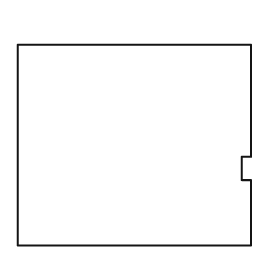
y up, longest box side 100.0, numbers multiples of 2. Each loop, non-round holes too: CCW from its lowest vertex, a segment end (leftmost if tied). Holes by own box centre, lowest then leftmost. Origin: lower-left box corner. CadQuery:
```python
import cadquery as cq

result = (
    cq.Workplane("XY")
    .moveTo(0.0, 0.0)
    .lineTo(100.0, 0.0)
    .lineTo(100.0, 28.0)
    .lineTo(96.0, 28.0)
    .lineTo(96.0, 38.0)
    .lineTo(100.0, 38.0)
    .lineTo(100.0, 86.0)
    .lineTo(0.0, 86.0)
    .close()
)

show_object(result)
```